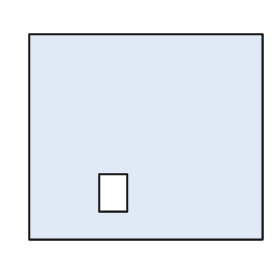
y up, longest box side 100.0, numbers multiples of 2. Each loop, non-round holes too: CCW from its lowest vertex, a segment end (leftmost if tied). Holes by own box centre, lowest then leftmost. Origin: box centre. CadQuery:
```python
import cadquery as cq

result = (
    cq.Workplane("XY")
    .moveTo(-50.0, -44.0)
    .lineTo(50.0, -44.0)
    .lineTo(50.0, 44.0)
    .lineTo(-50.0, 44.0)
    .close()
    .moveTo(-20.0, -32.0)
    .lineTo(-8.0, -32.0)
    .lineTo(-8.0, -16.0)
    .lineTo(-20.0, -16.0)
    .close()
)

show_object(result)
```